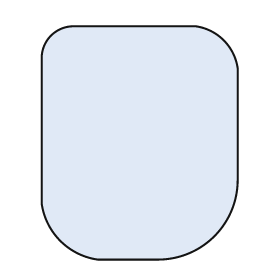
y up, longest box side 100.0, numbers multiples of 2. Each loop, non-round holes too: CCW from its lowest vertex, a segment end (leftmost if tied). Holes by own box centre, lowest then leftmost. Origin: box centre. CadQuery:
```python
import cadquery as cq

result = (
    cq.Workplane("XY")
    .moveTo(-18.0, -50.0)
    .lineTo(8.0, -50.0)
    .threePointArc((32.0, -40.0), (42.0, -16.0))
    .lineTo(42.0, 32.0)
    .threePointArc((36.0, 44.0), (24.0, 50.0))
    .lineTo(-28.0, 50.0)
    .threePointArc((-38.0, 46.0), (-42.0, 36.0))
    .lineTo(-42.0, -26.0)
    .threePointArc((-34.0, -42.0), (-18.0, -50.0))
    .close()
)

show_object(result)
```